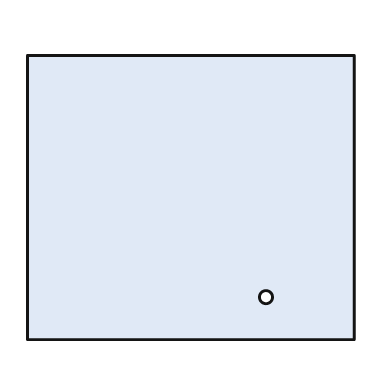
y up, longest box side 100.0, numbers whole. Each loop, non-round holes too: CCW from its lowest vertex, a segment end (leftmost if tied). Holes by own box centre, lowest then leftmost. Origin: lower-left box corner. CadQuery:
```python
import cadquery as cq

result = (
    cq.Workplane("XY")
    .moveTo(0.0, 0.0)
    .lineTo(100.0, 0.0)
    .lineTo(100.0, 87.0)
    .lineTo(0.0, 87.0)
    .close()
    .moveTo(73.0, 13.0)
    .circle(2.0)
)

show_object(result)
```